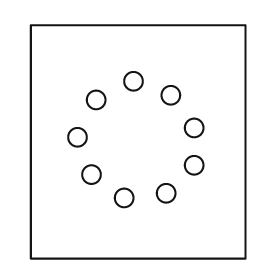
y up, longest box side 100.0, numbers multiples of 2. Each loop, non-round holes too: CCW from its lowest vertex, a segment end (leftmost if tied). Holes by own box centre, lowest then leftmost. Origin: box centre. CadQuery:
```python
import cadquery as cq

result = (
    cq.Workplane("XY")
    .moveTo(-46.0, -50.0)
    .lineTo(46.0, -50.0)
    .lineTo(46.0, 50.0)
    .lineTo(-46.0, 50.0)
    .close()
    .moveTo(-6.0, -24.0)
    .circle(4.0)
    .moveTo(12.0, -22.0)
    .circle(4.0)
    .moveTo(-20.0, -14.0)
    .circle(4.0)
    .moveTo(24.0, -10.0)
    .circle(4.0)
    .moveTo(-26.0, 2.0)
    .circle(4.0)
    .moveTo(24.0, 6.0)
    .circle(4.0)
    .moveTo(-18.0, 18.0)
    .circle(4.0)
    .moveTo(14.0, 20.0)
    .circle(4.0)
    .moveTo(-2.0, 26.0)
    .circle(4.0)
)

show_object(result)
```